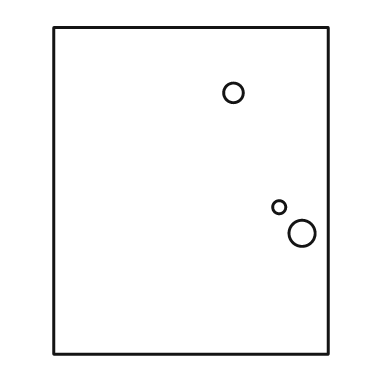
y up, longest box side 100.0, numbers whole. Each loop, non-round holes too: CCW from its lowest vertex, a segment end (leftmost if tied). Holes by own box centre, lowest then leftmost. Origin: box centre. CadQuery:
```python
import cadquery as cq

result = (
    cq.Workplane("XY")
    .moveTo(-42.0, -50.0)
    .lineTo(42.0, -50.0)
    .lineTo(42.0, 50.0)
    .lineTo(-42.0, 50.0)
    .close()
    .moveTo(34.0, -13.0)
    .circle(4.0)
    .moveTo(27.0, -5.0)
    .circle(2.0)
    .moveTo(13.0, 30.0)
    .circle(3.0)
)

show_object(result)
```